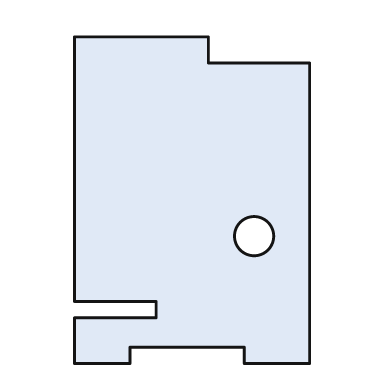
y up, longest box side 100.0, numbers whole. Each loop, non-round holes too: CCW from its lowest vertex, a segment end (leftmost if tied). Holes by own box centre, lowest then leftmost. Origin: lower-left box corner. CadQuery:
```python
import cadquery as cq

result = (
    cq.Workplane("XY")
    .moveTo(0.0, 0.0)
    .lineTo(17.0, 0.0)
    .lineTo(17.0, 5.0)
    .lineTo(52.0, 5.0)
    .lineTo(52.0, 0.0)
    .lineTo(72.0, 0.0)
    .lineTo(72.0, 92.0)
    .lineTo(41.0, 92.0)
    .lineTo(41.0, 100.0)
    .lineTo(0.0, 100.0)
    .lineTo(0.0, 19.0)
    .lineTo(25.0, 19.0)
    .lineTo(25.0, 14.0)
    .lineTo(0.0, 14.0)
    .close()
    .moveTo(55.0, 39.0)
    .circle(6.0)
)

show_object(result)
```